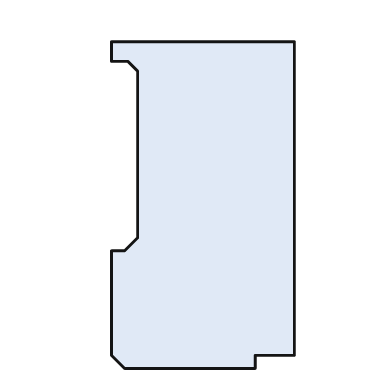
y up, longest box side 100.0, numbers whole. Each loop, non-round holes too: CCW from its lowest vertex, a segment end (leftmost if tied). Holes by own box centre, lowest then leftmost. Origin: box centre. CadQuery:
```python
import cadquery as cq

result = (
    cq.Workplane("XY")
    .moveTo(-24.0, -50.0)
    .lineTo(16.0, -50.0)
    .lineTo(16.0, -46.0)
    .lineTo(28.0, -46.0)
    .lineTo(28.0, 50.0)
    .lineTo(-28.0, 50.0)
    .lineTo(-28.0, 44.0)
    .lineTo(-23.0, 44.0)
    .lineTo(-20.0, 41.0)
    .lineTo(-20.0, -10.0)
    .lineTo(-24.0, -14.0)
    .lineTo(-28.0, -14.0)
    .lineTo(-28.0, -46.0)
    .close()
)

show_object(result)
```